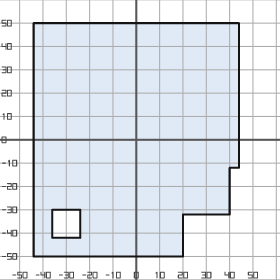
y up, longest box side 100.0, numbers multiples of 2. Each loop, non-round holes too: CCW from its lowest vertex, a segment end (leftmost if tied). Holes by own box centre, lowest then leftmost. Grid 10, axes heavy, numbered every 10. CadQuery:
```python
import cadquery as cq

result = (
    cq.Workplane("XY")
    .moveTo(-44.0, -50.0)
    .lineTo(20.0, -50.0)
    .lineTo(20.0, -32.0)
    .lineTo(40.0, -32.0)
    .lineTo(40.0, -12.0)
    .lineTo(44.0, -12.0)
    .lineTo(44.0, 50.0)
    .lineTo(-44.0, 50.0)
    .close()
    .moveTo(-36.0, -42.0)
    .lineTo(-24.0, -42.0)
    .lineTo(-24.0, -30.0)
    .lineTo(-36.0, -30.0)
    .close()
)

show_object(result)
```